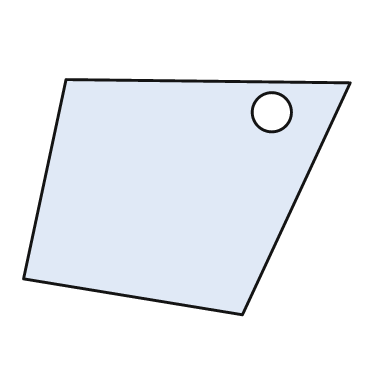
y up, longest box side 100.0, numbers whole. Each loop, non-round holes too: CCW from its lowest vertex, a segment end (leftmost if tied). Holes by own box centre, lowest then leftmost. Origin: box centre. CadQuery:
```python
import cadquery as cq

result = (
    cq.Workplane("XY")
    .moveTo(17.0, -36.0)
    .lineTo(50.0, 35.0)
    .lineTo(-37.0, 36.0)
    .lineTo(-50.0, -25.0)
    .close()
    .moveTo(26.0, 26.0)
    .circle(6.0)
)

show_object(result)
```